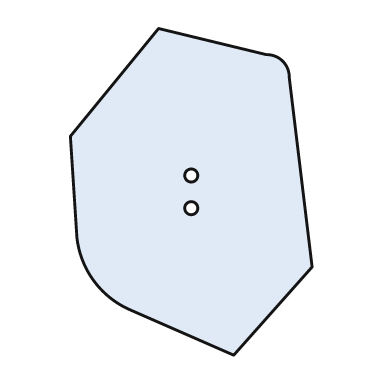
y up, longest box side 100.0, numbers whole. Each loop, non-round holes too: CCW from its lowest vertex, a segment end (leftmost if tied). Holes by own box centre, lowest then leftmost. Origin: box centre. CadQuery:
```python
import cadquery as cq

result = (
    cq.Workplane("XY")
    .moveTo(13.0, -50.0)
    .lineTo(37.0, -23.0)
    .lineTo(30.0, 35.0)
    .threePointArc((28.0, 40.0), (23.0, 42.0))
    .lineTo(-10.0, 50.0)
    .lineTo(-37.0, 17.0)
    .lineTo(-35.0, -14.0)
    .threePointArc((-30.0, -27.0), (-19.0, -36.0))
    .close()
    .moveTo(0.0, -5.0)
    .circle(2.0)
    .moveTo(0.0, 5.0)
    .circle(2.0)
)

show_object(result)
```